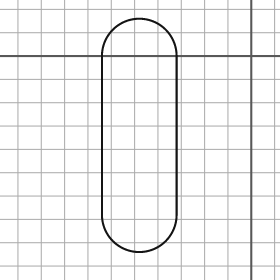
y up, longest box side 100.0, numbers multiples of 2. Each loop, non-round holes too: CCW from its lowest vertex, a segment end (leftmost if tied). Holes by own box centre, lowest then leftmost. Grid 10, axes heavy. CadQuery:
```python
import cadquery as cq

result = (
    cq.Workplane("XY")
    .moveTo(-64.0, -68.0)
    .threePointArc((-48.0, -84.0), (-32.0, -68.0))
    .lineTo(-32.0, 0.0)
    .threePointArc((-48.0, 16.0), (-64.0, 0.0))
    .close()
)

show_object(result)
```